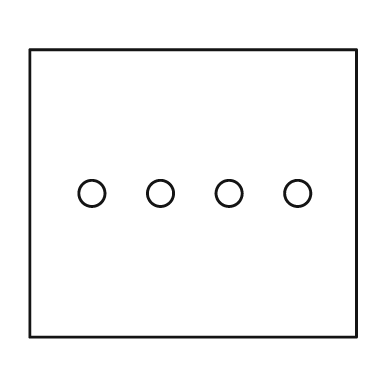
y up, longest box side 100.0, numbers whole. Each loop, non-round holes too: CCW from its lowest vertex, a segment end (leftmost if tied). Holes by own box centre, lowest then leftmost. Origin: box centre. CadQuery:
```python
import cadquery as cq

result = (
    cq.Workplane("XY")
    .moveTo(-50.0, -44.0)
    .lineTo(50.0, -44.0)
    .lineTo(50.0, 44.0)
    .lineTo(-50.0, 44.0)
    .close()
    .moveTo(-31.0, 0.0)
    .circle(4.0)
    .moveTo(-10.0, 0.0)
    .circle(4.0)
    .moveTo(11.0, 0.0)
    .circle(4.0)
    .moveTo(32.0, 0.0)
    .circle(4.0)
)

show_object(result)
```